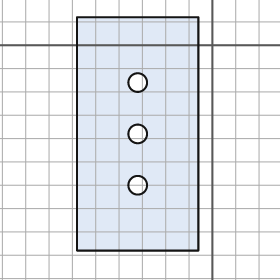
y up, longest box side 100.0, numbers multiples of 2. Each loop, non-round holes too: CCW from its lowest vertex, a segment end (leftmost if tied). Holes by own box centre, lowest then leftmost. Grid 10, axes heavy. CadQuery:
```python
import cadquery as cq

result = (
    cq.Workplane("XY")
    .moveTo(-58.0, -88.0)
    .lineTo(-6.0, -88.0)
    .lineTo(-6.0, 12.0)
    .lineTo(-58.0, 12.0)
    .close()
    .moveTo(-32.0, -60.0)
    .circle(4.0)
    .moveTo(-32.0, -38.0)
    .circle(4.0)
    .moveTo(-32.0, -16.0)
    .circle(4.0)
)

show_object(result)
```